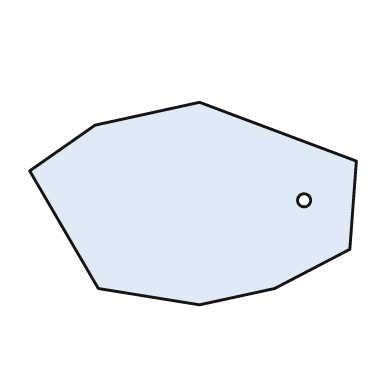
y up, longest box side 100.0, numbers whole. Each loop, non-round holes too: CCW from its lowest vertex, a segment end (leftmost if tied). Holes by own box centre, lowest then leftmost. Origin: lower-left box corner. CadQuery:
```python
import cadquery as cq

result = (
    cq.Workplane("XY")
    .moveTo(52.0, 0.0)
    .lineTo(75.0, 5.0)
    .lineTo(98.0, 17.0)
    .lineTo(100.0, 44.0)
    .lineTo(52.0, 62.0)
    .lineTo(20.0, 55.0)
    .lineTo(0.0, 41.0)
    .lineTo(21.0, 5.0)
    .close()
    .moveTo(84.0, 32.0)
    .circle(2.0)
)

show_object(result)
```